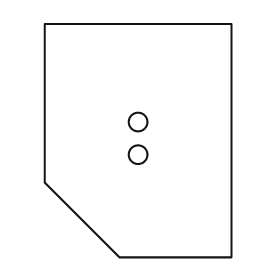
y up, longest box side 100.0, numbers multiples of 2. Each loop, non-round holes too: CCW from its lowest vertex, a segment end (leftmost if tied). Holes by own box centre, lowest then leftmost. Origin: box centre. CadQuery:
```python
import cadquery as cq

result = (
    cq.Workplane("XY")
    .moveTo(-8.0, -50.0)
    .lineTo(40.0, -50.0)
    .lineTo(40.0, 50.0)
    .lineTo(-40.0, 50.0)
    .lineTo(-40.0, -18.0)
    .close()
    .moveTo(0.0, -6.0)
    .circle(4.0)
    .moveTo(0.0, 8.0)
    .circle(4.0)
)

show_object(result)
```